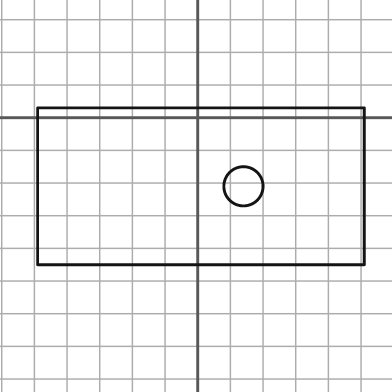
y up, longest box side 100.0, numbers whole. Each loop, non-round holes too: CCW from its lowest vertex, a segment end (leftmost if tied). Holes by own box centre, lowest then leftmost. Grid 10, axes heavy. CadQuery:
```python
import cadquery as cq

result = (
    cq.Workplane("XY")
    .moveTo(-49.0, -45.0)
    .lineTo(51.0, -45.0)
    .lineTo(51.0, 3.0)
    .lineTo(-49.0, 3.0)
    .close()
    .moveTo(14.0, -21.0)
    .circle(6.0)
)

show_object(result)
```